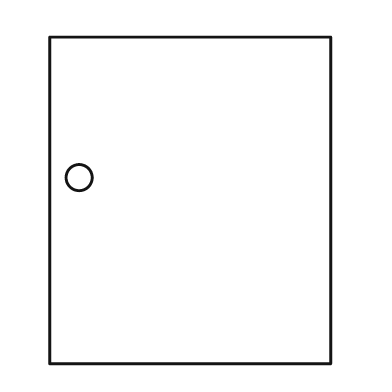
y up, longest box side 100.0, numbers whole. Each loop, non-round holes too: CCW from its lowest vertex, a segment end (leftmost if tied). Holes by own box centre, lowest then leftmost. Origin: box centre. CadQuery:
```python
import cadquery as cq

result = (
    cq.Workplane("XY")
    .moveTo(-43.0, -50.0)
    .lineTo(43.0, -50.0)
    .lineTo(43.0, 50.0)
    .lineTo(-43.0, 50.0)
    .close()
    .moveTo(-34.0, 7.0)
    .circle(4.0)
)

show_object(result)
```